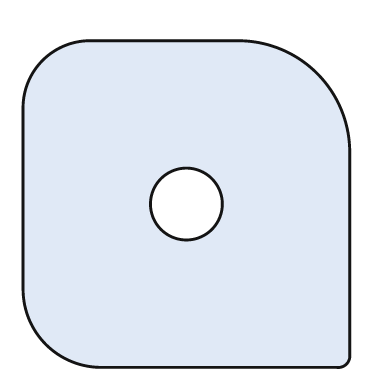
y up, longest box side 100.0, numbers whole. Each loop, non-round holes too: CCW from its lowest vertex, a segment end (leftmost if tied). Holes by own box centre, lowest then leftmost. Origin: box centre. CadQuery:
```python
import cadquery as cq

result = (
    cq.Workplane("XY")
    .moveTo(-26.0, -50.0)
    .lineTo(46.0, -50.0)
    .threePointArc((49.0, -49.0), (50.0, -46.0))
    .lineTo(50.0, 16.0)
    .threePointArc((40.0, 40.0), (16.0, 50.0))
    .lineTo(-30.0, 50.0)
    .threePointArc((-44.0, 44.0), (-50.0, 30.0))
    .lineTo(-50.0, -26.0)
    .threePointArc((-43.0, -43.0), (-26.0, -50.0))
    .close()
    .moveTo(0.0, 0.0)
    .circle(11.0)
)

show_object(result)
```